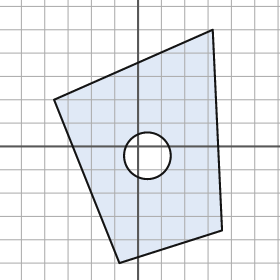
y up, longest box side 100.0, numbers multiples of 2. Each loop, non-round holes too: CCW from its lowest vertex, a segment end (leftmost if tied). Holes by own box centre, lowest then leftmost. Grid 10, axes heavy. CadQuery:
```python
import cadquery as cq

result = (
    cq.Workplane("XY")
    .moveTo(-8.0, -50.0)
    .lineTo(36.0, -36.0)
    .lineTo(32.0, 50.0)
    .lineTo(-36.0, 20.0)
    .close()
    .moveTo(4.0, -4.0)
    .circle(10.0)
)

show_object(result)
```